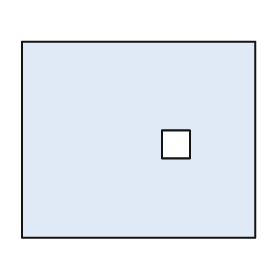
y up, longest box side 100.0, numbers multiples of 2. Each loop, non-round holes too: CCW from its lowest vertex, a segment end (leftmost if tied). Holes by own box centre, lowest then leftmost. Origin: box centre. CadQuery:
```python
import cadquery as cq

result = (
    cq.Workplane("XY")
    .moveTo(-50.0, -42.0)
    .lineTo(50.0, -42.0)
    .lineTo(50.0, 42.0)
    .lineTo(-50.0, 42.0)
    .close()
    .moveTo(10.0, -8.0)
    .lineTo(22.0, -8.0)
    .lineTo(22.0, 4.0)
    .lineTo(10.0, 4.0)
    .close()
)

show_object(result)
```